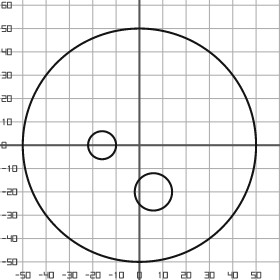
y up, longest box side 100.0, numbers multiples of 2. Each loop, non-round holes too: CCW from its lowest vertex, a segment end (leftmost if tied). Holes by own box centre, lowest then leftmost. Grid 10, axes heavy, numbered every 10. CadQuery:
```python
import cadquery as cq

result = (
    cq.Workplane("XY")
    .moveTo(0.0, 0.0)
    .circle(50.0)
    .moveTo(6.0, -20.0)
    .circle(8.0)
    .moveTo(-16.0, 0.0)
    .circle(6.0)
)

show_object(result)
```